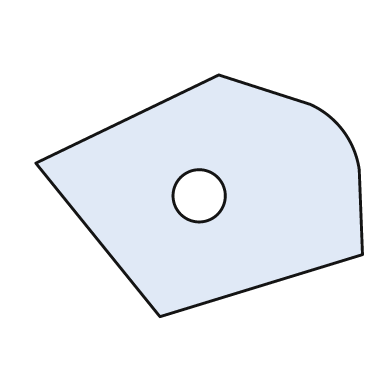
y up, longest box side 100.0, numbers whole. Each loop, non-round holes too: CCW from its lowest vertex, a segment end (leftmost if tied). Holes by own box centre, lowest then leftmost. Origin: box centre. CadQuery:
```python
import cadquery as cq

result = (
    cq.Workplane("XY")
    .moveTo(-12.0, -37.0)
    .lineTo(50.0, -18.0)
    .lineTo(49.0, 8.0)
    .threePointArc((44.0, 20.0), (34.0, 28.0))
    .lineTo(6.0, 37.0)
    .lineTo(-50.0, 10.0)
    .close()
    .moveTo(0.0, 0.0)
    .circle(8.0)
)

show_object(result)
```